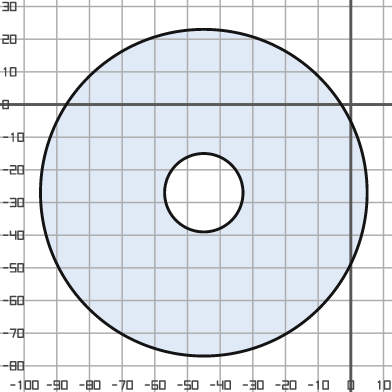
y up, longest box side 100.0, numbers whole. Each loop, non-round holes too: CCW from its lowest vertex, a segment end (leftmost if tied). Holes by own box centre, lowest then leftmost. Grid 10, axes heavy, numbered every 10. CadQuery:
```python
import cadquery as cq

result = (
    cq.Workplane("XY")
    .moveTo(-45.0, -27.0)
    .circle(50.0)
    .moveTo(-45.0, -27.0)
    .circle(12.0)
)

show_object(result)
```